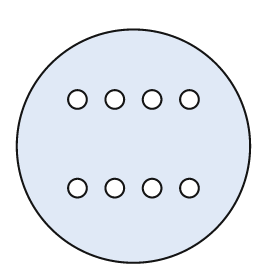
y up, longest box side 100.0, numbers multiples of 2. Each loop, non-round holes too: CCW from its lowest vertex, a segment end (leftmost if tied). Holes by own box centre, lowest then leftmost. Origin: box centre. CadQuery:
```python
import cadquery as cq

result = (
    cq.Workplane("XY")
    .moveTo(0.0, 0.0)
    .circle(50.0)
    .moveTo(-24.0, -18.0)
    .circle(4.0)
    .moveTo(-8.0, -18.0)
    .circle(4.0)
    .moveTo(8.0, -18.0)
    .circle(4.0)
    .moveTo(24.0, -18.0)
    .circle(4.0)
    .moveTo(-24.0, 20.0)
    .circle(4.0)
    .moveTo(-8.0, 20.0)
    .circle(4.0)
    .moveTo(8.0, 20.0)
    .circle(4.0)
    .moveTo(24.0, 20.0)
    .circle(4.0)
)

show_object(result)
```